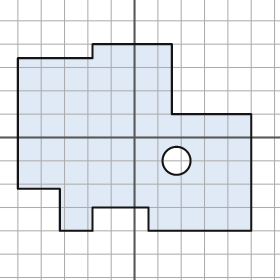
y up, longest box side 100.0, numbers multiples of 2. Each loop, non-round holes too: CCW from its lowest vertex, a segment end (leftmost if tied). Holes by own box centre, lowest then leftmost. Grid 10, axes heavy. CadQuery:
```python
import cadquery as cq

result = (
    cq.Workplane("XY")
    .moveTo(-32.0, -40.0)
    .lineTo(-18.0, -40.0)
    .lineTo(-18.0, -30.0)
    .lineTo(6.0, -30.0)
    .lineTo(6.0, -40.0)
    .lineTo(50.0, -40.0)
    .lineTo(50.0, 10.0)
    .lineTo(16.0, 10.0)
    .lineTo(16.0, 40.0)
    .lineTo(-18.0, 40.0)
    .lineTo(-18.0, 34.0)
    .lineTo(-50.0, 34.0)
    .lineTo(-50.0, -22.0)
    .lineTo(-32.0, -22.0)
    .close()
    .moveTo(18.0, -10.0)
    .circle(6.0)
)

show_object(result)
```